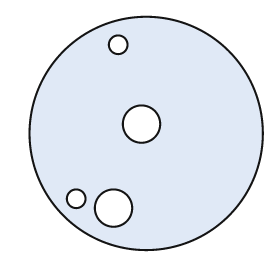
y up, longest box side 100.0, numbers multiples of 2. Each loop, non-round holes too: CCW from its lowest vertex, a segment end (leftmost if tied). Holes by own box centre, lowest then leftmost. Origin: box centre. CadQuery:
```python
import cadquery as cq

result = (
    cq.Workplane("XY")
    .moveTo(0.0, 0.0)
    .circle(50.0)
    .moveTo(-14.0, -32.0)
    .circle(8.0)
    .moveTo(-30.0, -28.0)
    .circle(4.0)
    .moveTo(-2.0, 4.0)
    .circle(8.0)
    .moveTo(-12.0, 38.0)
    .circle(4.0)
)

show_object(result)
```